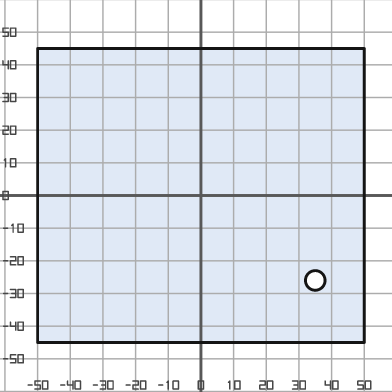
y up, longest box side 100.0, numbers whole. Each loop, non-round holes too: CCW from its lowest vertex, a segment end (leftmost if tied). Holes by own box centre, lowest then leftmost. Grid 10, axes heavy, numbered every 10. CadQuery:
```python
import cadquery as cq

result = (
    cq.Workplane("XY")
    .moveTo(-50.0, -45.0)
    .lineTo(50.0, -45.0)
    .lineTo(50.0, 45.0)
    .lineTo(-50.0, 45.0)
    .close()
    .moveTo(35.0, -26.0)
    .circle(3.0)
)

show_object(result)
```